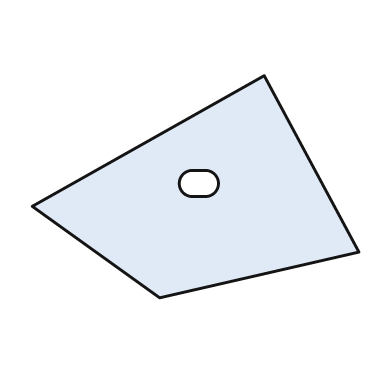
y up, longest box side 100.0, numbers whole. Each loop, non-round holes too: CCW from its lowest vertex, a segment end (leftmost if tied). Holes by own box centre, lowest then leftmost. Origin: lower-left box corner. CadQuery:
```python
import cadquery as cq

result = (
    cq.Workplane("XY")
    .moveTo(39.0, 0.0)
    .lineTo(100.0, 14.0)
    .lineTo(71.0, 68.0)
    .lineTo(0.0, 28.0)
    .close()
    .moveTo(49.0, 31.0)
    .lineTo(53.0, 31.0)
    .threePointArc((57.0, 35.0), (53.0, 39.0))
    .lineTo(49.0, 39.0)
    .threePointArc((45.0, 35.0), (49.0, 31.0))
    .close()
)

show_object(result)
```